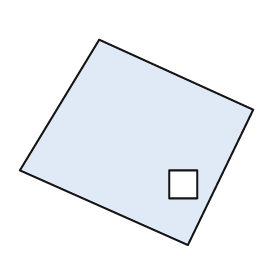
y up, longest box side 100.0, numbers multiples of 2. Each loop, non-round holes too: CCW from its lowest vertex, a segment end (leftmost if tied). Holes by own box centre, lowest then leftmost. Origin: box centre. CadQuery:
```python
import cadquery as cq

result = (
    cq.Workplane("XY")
    .moveTo(22.0, -44.0)
    .lineTo(50.0, 14.0)
    .lineTo(-16.0, 44.0)
    .lineTo(-50.0, -12.0)
    .close()
    .moveTo(14.0, -24.0)
    .lineTo(26.0, -24.0)
    .lineTo(26.0, -12.0)
    .lineTo(14.0, -12.0)
    .close()
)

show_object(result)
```